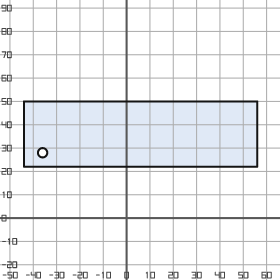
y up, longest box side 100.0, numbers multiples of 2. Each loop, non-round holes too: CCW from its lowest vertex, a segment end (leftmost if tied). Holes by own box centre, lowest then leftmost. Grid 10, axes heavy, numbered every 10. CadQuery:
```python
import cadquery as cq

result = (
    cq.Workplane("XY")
    .moveTo(-44.0, 22.0)
    .lineTo(56.0, 22.0)
    .lineTo(56.0, 50.0)
    .lineTo(-44.0, 50.0)
    .close()
    .moveTo(-36.0, 28.0)
    .circle(2.0)
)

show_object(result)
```